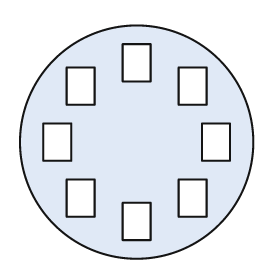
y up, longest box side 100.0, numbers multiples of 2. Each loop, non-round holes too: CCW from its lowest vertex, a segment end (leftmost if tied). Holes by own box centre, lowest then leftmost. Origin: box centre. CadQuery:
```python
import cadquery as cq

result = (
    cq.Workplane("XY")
    .moveTo(0.0, 0.0)
    .circle(50.0)
    .moveTo(-6.0, -42.0)
    .lineTo(6.0, -42.0)
    .lineTo(6.0, -26.0)
    .lineTo(-6.0, -26.0)
    .close()
    .moveTo(-30.0, -32.0)
    .lineTo(-18.0, -32.0)
    .lineTo(-18.0, -16.0)
    .lineTo(-30.0, -16.0)
    .close()
    .moveTo(18.0, -32.0)
    .lineTo(30.0, -32.0)
    .lineTo(30.0, -16.0)
    .lineTo(18.0, -16.0)
    .close()
    .moveTo(-40.0, -8.0)
    .lineTo(-28.0, -8.0)
    .lineTo(-28.0, 8.0)
    .lineTo(-40.0, 8.0)
    .close()
    .moveTo(28.0, -8.0)
    .lineTo(40.0, -8.0)
    .lineTo(40.0, 8.0)
    .lineTo(28.0, 8.0)
    .close()
    .moveTo(-30.0, 16.0)
    .lineTo(-18.0, 16.0)
    .lineTo(-18.0, 32.0)
    .lineTo(-30.0, 32.0)
    .close()
    .moveTo(18.0, 16.0)
    .lineTo(30.0, 16.0)
    .lineTo(30.0, 32.0)
    .lineTo(18.0, 32.0)
    .close()
    .moveTo(-6.0, 26.0)
    .lineTo(6.0, 26.0)
    .lineTo(6.0, 42.0)
    .lineTo(-6.0, 42.0)
    .close()
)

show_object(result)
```